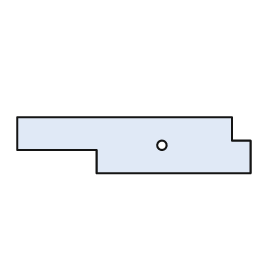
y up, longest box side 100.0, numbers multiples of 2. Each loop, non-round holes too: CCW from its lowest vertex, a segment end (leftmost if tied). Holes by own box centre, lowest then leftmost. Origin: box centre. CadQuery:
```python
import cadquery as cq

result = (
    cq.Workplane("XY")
    .moveTo(-16.0, -12.0)
    .lineTo(50.0, -12.0)
    .lineTo(50.0, 2.0)
    .lineTo(42.0, 2.0)
    .lineTo(42.0, 12.0)
    .lineTo(-50.0, 12.0)
    .lineTo(-50.0, -2.0)
    .lineTo(-16.0, -2.0)
    .close()
    .moveTo(12.0, 0.0)
    .circle(2.0)
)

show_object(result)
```